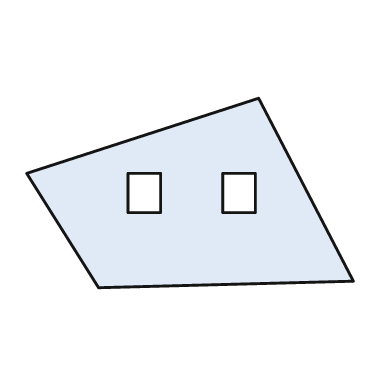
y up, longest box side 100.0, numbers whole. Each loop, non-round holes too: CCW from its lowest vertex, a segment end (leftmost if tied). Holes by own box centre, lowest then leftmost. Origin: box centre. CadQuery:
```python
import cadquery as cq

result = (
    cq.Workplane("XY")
    .moveTo(-28.0, -29.0)
    .lineTo(50.0, -27.0)
    .lineTo(21.0, 29.0)
    .lineTo(-50.0, 6.0)
    .close()
    .moveTo(-19.0, -6.0)
    .lineTo(-9.0, -6.0)
    .lineTo(-9.0, 6.0)
    .lineTo(-19.0, 6.0)
    .close()
    .moveTo(10.0, -6.0)
    .lineTo(20.0, -6.0)
    .lineTo(20.0, 6.0)
    .lineTo(10.0, 6.0)
    .close()
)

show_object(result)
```